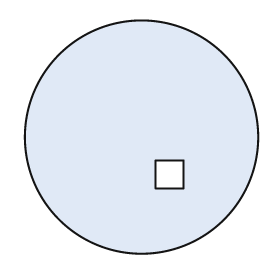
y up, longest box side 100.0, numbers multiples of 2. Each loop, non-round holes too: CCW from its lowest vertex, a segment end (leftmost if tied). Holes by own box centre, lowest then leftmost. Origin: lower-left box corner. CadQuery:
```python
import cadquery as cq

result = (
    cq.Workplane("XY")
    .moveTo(50.0, 50.0)
    .circle(50.0)
    .moveTo(56.0, 28.0)
    .lineTo(68.0, 28.0)
    .lineTo(68.0, 40.0)
    .lineTo(56.0, 40.0)
    .close()
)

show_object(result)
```